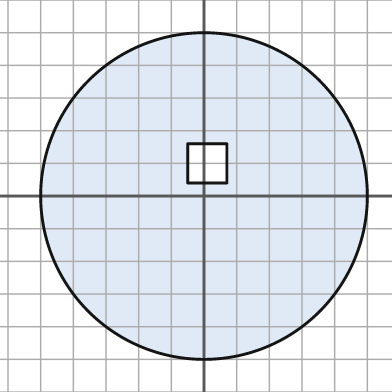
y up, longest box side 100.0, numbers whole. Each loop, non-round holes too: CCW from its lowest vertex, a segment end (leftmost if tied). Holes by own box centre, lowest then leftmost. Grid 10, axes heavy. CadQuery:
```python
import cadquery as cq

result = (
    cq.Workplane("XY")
    .moveTo(0.0, 0.0)
    .circle(50.0)
    .moveTo(-5.0, 4.0)
    .lineTo(7.0, 4.0)
    .lineTo(7.0, 16.0)
    .lineTo(-5.0, 16.0)
    .close()
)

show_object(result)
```